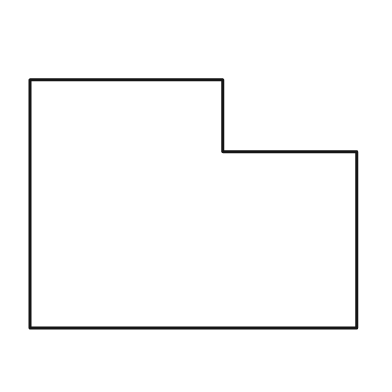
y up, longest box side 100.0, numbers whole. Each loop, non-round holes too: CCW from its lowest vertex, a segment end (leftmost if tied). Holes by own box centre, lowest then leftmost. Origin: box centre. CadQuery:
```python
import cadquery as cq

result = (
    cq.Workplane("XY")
    .moveTo(-50.0, -38.0)
    .lineTo(50.0, -38.0)
    .lineTo(50.0, 16.0)
    .lineTo(9.0, 16.0)
    .lineTo(9.0, 38.0)
    .lineTo(-50.0, 38.0)
    .close()
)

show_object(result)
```